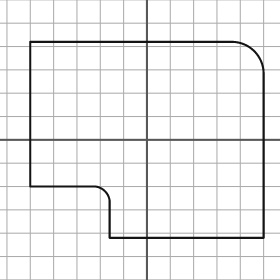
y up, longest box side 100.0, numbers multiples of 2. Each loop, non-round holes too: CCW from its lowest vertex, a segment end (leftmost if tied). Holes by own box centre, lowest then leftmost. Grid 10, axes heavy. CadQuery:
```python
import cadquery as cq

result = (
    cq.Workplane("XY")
    .moveTo(-16.0, -42.0)
    .lineTo(50.0, -42.0)
    .lineTo(50.0, 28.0)
    .threePointArc((46.0, 38.0), (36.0, 42.0))
    .lineTo(-50.0, 42.0)
    .lineTo(-50.0, -20.0)
    .lineTo(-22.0, -20.0)
    .threePointArc((-18.0, -22.0), (-16.0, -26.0))
    .close()
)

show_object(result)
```